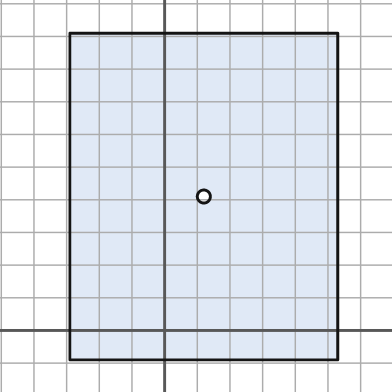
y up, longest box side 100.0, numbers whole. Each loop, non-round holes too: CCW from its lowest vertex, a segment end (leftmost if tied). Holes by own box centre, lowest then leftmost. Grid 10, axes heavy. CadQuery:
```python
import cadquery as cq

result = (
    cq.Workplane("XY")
    .moveTo(-29.0, -9.0)
    .lineTo(53.0, -9.0)
    .lineTo(53.0, 91.0)
    .lineTo(-29.0, 91.0)
    .close()
    .moveTo(12.0, 41.0)
    .circle(2.0)
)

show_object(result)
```